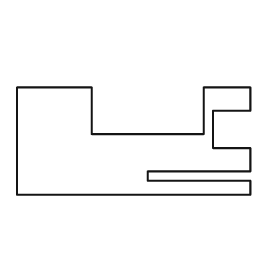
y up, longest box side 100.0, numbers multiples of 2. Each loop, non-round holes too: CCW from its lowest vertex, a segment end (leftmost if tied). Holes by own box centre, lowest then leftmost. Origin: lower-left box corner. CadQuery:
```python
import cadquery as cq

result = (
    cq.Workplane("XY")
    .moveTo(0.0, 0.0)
    .lineTo(100.0, 0.0)
    .lineTo(100.0, 6.0)
    .lineTo(56.0, 6.0)
    .lineTo(56.0, 10.0)
    .lineTo(100.0, 10.0)
    .lineTo(100.0, 20.0)
    .lineTo(84.0, 20.0)
    .lineTo(84.0, 36.0)
    .lineTo(100.0, 36.0)
    .lineTo(100.0, 46.0)
    .lineTo(80.0, 46.0)
    .lineTo(80.0, 26.0)
    .lineTo(32.0, 26.0)
    .lineTo(32.0, 46.0)
    .lineTo(0.0, 46.0)
    .close()
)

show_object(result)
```